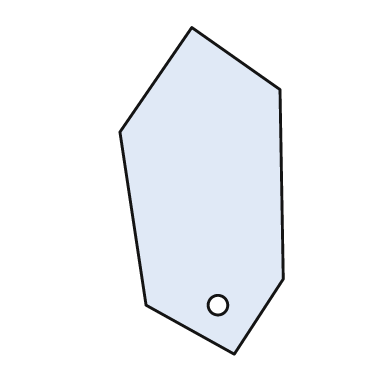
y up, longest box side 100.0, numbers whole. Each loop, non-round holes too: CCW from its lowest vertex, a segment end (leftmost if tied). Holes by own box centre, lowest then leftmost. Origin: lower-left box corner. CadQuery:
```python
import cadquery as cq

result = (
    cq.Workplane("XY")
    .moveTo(35.0, 0.0)
    .lineTo(50.0, 23.0)
    .lineTo(49.0, 81.0)
    .lineTo(22.0, 100.0)
    .lineTo(0.0, 68.0)
    .lineTo(8.0, 15.0)
    .close()
    .moveTo(30.0, 15.0)
    .circle(3.0)
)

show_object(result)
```